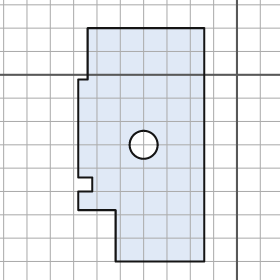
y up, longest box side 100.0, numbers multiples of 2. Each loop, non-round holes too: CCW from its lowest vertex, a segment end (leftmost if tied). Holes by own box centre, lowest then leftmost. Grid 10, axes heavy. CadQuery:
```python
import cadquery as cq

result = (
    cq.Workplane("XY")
    .moveTo(-52.0, -80.0)
    .lineTo(-14.0, -80.0)
    .lineTo(-14.0, 20.0)
    .lineTo(-64.0, 20.0)
    .lineTo(-64.0, -2.0)
    .lineTo(-68.0, -2.0)
    .lineTo(-68.0, -44.0)
    .lineTo(-62.0, -44.0)
    .lineTo(-62.0, -50.0)
    .lineTo(-68.0, -50.0)
    .lineTo(-68.0, -58.0)
    .lineTo(-52.0, -58.0)
    .close()
    .moveTo(-40.0, -30.0)
    .circle(6.0)
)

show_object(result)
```